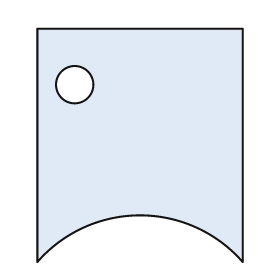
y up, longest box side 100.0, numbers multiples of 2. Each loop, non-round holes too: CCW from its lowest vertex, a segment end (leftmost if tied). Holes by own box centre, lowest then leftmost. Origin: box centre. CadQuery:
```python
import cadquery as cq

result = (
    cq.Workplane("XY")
    .moveTo(-44.0, -50.0)
    .threePointArc((0.0, -30.0), (44.0, -50.0))
    .lineTo(44.0, 50.0)
    .lineTo(-44.0, 50.0)
    .close()
    .moveTo(-28.0, 26.0)
    .circle(8.0)
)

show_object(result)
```